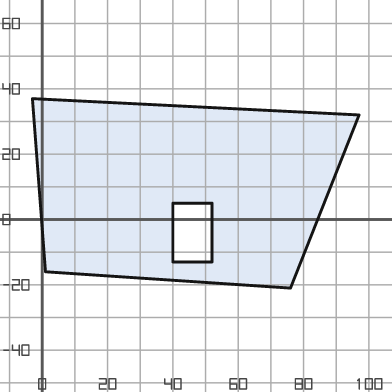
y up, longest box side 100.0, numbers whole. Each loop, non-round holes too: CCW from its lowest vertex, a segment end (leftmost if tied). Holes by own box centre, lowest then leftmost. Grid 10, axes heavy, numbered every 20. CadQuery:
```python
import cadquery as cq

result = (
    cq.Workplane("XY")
    .moveTo(76.0, -21.0)
    .lineTo(97.0, 32.0)
    .lineTo(-3.0, 37.0)
    .lineTo(1.0, -16.0)
    .close()
    .moveTo(40.0, -13.0)
    .lineTo(52.0, -13.0)
    .lineTo(52.0, 5.0)
    .lineTo(40.0, 5.0)
    .close()
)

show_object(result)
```